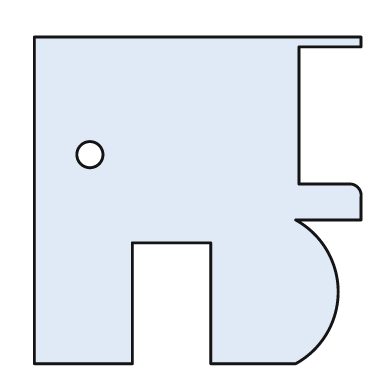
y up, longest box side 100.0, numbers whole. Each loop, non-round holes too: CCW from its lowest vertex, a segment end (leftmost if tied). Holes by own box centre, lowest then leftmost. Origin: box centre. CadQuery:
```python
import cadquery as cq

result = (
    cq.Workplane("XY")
    .moveTo(-50.0, -50.0)
    .lineTo(-20.0, -50.0)
    .lineTo(-20.0, -13.0)
    .lineTo(4.0, -13.0)
    .lineTo(4.0, -50.0)
    .lineTo(30.0, -50.0)
    .threePointArc((43.0, -28.0), (30.0, -6.0))
    .lineTo(50.0, -6.0)
    .lineTo(50.0, 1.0)
    .threePointArc((49.0, 4.0), (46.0, 5.0))
    .lineTo(31.0, 5.0)
    .lineTo(31.0, 47.0)
    .lineTo(50.0, 47.0)
    .lineTo(50.0, 50.0)
    .lineTo(-50.0, 50.0)
    .close()
    .moveTo(-33.0, 14.0)
    .circle(4.0)
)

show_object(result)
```